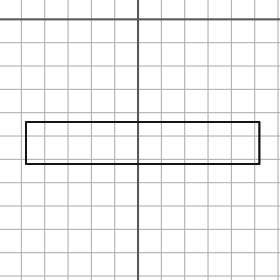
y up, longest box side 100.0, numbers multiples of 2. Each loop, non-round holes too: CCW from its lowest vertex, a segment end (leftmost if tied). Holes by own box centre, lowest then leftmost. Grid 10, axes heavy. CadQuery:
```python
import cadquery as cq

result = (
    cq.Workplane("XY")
    .moveTo(-48.0, -62.0)
    .lineTo(52.0, -62.0)
    .lineTo(52.0, -44.0)
    .lineTo(-48.0, -44.0)
    .close()
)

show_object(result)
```